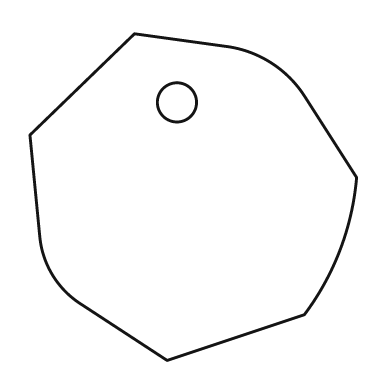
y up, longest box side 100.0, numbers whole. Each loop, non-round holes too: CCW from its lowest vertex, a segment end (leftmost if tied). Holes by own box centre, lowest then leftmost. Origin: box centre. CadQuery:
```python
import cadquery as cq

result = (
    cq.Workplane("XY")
    .moveTo(-8.0, -50.0)
    .lineTo(34.0, -36.0)
    .threePointArc((45.0, -16.0), (50.0, 6.0))
    .lineTo(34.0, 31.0)
    .threePointArc((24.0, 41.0), (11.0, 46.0))
    .lineTo(-18.0, 50.0)
    .lineTo(-50.0, 19.0)
    .lineTo(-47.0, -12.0)
    .threePointArc((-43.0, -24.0), (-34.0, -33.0))
    .close()
    .moveTo(-5.0, 29.0)
    .circle(6.0)
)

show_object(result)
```